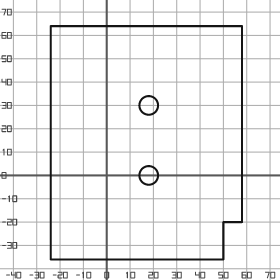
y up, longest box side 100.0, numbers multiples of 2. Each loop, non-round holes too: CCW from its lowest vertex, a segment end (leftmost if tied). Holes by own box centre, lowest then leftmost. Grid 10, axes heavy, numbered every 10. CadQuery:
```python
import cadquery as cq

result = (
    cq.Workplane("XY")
    .moveTo(-24.0, -36.0)
    .lineTo(50.0, -36.0)
    .lineTo(50.0, -20.0)
    .lineTo(58.0, -20.0)
    .lineTo(58.0, 64.0)
    .lineTo(-24.0, 64.0)
    .close()
    .moveTo(18.0, 0.0)
    .circle(4.0)
    .moveTo(18.0, 30.0)
    .circle(4.0)
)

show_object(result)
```